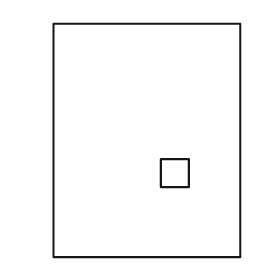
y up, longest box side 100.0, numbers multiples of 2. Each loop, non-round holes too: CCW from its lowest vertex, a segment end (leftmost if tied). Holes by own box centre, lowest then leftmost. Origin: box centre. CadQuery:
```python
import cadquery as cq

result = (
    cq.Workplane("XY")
    .moveTo(-40.0, -50.0)
    .lineTo(40.0, -50.0)
    .lineTo(40.0, 50.0)
    .lineTo(-40.0, 50.0)
    .close()
    .moveTo(6.0, -20.0)
    .lineTo(18.0, -20.0)
    .lineTo(18.0, -8.0)
    .lineTo(6.0, -8.0)
    .close()
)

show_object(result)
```